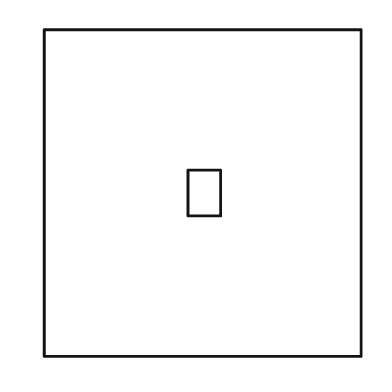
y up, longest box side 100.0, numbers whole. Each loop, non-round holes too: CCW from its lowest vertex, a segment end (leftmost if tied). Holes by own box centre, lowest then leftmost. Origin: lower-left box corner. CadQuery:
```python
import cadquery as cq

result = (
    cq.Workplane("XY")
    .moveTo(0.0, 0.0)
    .lineTo(97.0, 0.0)
    .lineTo(97.0, 100.0)
    .lineTo(0.0, 100.0)
    .close()
    .moveTo(44.0, 43.0)
    .lineTo(54.0, 43.0)
    .lineTo(54.0, 57.0)
    .lineTo(44.0, 57.0)
    .close()
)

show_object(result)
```